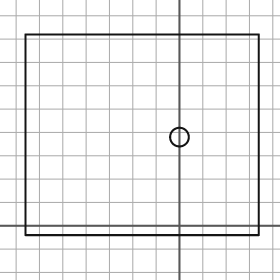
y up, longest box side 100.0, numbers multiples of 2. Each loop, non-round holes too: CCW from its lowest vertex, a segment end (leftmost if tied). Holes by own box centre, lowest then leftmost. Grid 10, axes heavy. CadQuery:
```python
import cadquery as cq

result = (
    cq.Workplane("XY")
    .moveTo(-66.0, -4.0)
    .lineTo(34.0, -4.0)
    .lineTo(34.0, 82.0)
    .lineTo(-66.0, 82.0)
    .close()
    .moveTo(0.0, 38.0)
    .circle(4.0)
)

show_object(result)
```